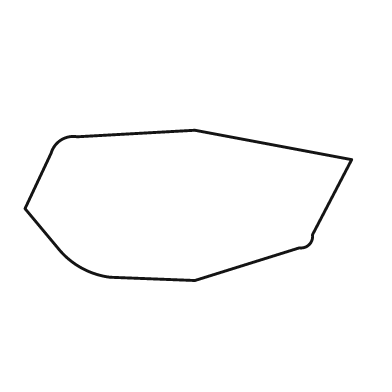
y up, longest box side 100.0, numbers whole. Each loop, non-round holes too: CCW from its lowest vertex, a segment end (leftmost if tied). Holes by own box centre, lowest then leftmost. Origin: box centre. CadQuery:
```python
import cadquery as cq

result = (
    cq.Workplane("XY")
    .moveTo(2.0, -23.0)
    .lineTo(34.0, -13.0)
    .threePointArc((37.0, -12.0), (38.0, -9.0))
    .lineTo(50.0, 14.0)
    .lineTo(2.0, 23.0)
    .lineTo(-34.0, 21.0)
    .threePointArc((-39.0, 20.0), (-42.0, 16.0))
    .lineTo(-50.0, -1.0)
    .lineTo(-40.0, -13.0)
    .threePointArc((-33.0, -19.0), (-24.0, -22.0))
    .close()
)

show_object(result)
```